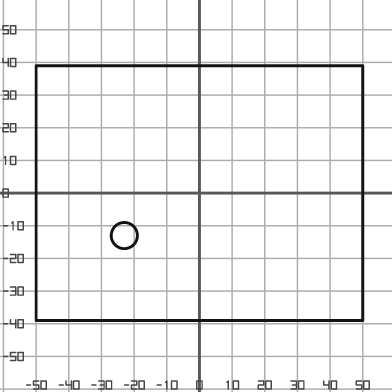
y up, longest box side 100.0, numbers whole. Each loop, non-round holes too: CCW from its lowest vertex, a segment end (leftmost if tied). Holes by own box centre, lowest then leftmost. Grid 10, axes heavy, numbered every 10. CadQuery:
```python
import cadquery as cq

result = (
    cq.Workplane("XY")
    .moveTo(-50.0, -39.0)
    .lineTo(50.0, -39.0)
    .lineTo(50.0, 39.0)
    .lineTo(-50.0, 39.0)
    .close()
    .moveTo(-23.0, -13.0)
    .circle(4.0)
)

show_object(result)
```